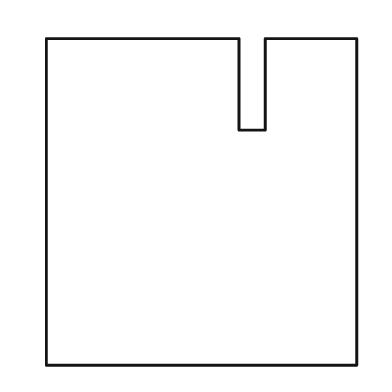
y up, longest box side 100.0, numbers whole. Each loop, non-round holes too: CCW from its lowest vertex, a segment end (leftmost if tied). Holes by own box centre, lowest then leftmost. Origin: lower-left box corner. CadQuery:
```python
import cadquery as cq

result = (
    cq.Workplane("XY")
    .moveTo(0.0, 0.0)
    .lineTo(95.0, 0.0)
    .lineTo(95.0, 100.0)
    .lineTo(67.0, 100.0)
    .lineTo(67.0, 72.0)
    .lineTo(59.0, 72.0)
    .lineTo(59.0, 100.0)
    .lineTo(0.0, 100.0)
    .close()
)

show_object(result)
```